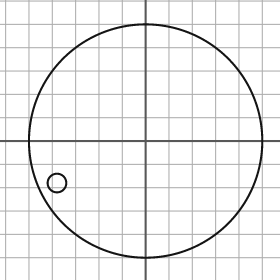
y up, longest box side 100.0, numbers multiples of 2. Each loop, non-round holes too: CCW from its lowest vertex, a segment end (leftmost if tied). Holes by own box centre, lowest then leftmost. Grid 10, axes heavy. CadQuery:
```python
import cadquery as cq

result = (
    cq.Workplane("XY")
    .moveTo(0.0, 0.0)
    .circle(50.0)
    .moveTo(-38.0, -18.0)
    .circle(4.0)
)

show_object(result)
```